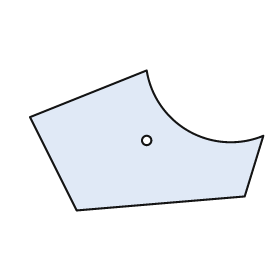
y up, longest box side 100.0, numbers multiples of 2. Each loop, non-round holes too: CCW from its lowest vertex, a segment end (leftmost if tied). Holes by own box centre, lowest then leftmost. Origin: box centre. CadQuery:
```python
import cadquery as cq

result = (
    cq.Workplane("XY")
    .moveTo(-30.0, -30.0)
    .lineTo(42.0, -24.0)
    .lineTo(50.0, 2.0)
    .threePointArc((18.0, 4.0), (0.0, 30.0))
    .lineTo(-50.0, 10.0)
    .close()
    .moveTo(0.0, 0.0)
    .circle(2.0)
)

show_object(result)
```